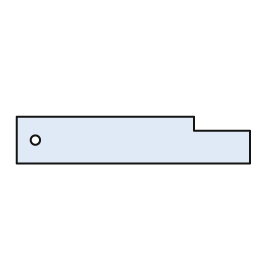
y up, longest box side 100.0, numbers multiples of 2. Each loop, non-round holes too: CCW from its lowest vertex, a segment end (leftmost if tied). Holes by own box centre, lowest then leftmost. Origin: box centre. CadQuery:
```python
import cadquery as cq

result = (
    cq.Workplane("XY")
    .moveTo(-50.0, -10.0)
    .lineTo(50.0, -10.0)
    .lineTo(50.0, 4.0)
    .lineTo(26.0, 4.0)
    .lineTo(26.0, 10.0)
    .lineTo(-50.0, 10.0)
    .close()
    .moveTo(-42.0, 0.0)
    .circle(2.0)
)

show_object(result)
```